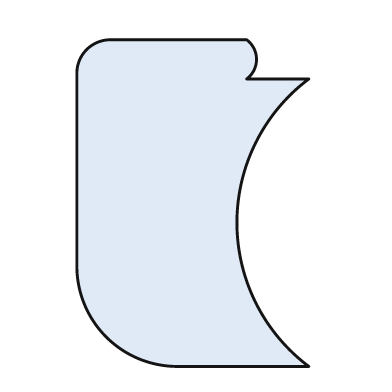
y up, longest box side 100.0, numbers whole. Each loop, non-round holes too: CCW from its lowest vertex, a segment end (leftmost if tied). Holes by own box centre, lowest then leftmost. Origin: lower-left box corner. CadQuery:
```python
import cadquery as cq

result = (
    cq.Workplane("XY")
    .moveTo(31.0, 0.0)
    .lineTo(71.0, 0.0)
    .threePointArc((49.0, 44.0), (71.0, 88.0))
    .lineTo(52.0, 88.0)
    .threePointArc((55.0, 94.0), (52.0, 100.0))
    .lineTo(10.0, 100.0)
    .threePointArc((3.0, 97.0), (0.0, 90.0))
    .lineTo(0.0, 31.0)
    .threePointArc((9.0, 9.0), (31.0, 0.0))
    .close()
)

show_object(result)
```